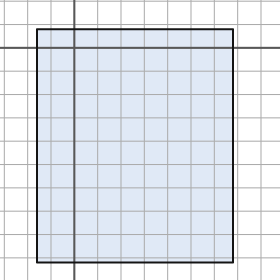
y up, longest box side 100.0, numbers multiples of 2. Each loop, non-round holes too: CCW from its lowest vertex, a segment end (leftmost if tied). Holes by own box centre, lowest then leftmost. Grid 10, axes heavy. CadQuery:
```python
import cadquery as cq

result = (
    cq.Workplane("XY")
    .moveTo(-16.0, -92.0)
    .lineTo(68.0, -92.0)
    .lineTo(68.0, 8.0)
    .lineTo(-16.0, 8.0)
    .close()
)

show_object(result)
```